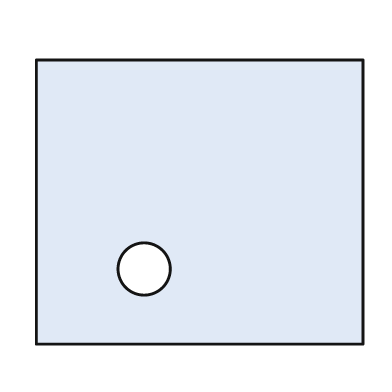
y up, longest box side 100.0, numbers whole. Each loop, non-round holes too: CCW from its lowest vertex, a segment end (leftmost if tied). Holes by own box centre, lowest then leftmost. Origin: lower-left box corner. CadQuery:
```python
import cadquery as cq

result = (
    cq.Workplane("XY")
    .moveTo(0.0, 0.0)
    .lineTo(100.0, 0.0)
    .lineTo(100.0, 87.0)
    .lineTo(0.0, 87.0)
    .close()
    .moveTo(33.0, 23.0)
    .circle(8.0)
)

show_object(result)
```